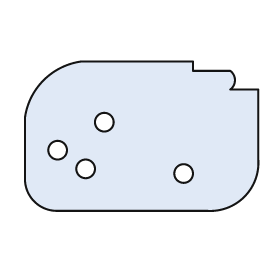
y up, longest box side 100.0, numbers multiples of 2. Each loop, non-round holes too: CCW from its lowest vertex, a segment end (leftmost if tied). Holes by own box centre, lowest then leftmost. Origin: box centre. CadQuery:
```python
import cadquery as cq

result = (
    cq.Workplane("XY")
    .moveTo(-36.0, -32.0)
    .lineTo(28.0, -32.0)
    .threePointArc((44.0, -26.0), (50.0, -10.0))
    .lineTo(50.0, 20.0)
    .lineTo(38.0, 20.0)
    .threePointArc((40.0, 24.0), (38.0, 28.0))
    .lineTo(22.0, 28.0)
    .lineTo(22.0, 32.0)
    .lineTo(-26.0, 32.0)
    .threePointArc((-42.0, 24.0), (-50.0, 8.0))
    .lineTo(-50.0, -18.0)
    .threePointArc((-46.0, -28.0), (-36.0, -32.0))
    .close()
    .moveTo(18.0, -16.0)
    .circle(4.0)
    .moveTo(-24.0, -14.0)
    .circle(4.0)
    .moveTo(-36.0, -6.0)
    .circle(4.0)
    .moveTo(-16.0, 6.0)
    .circle(4.0)
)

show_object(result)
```